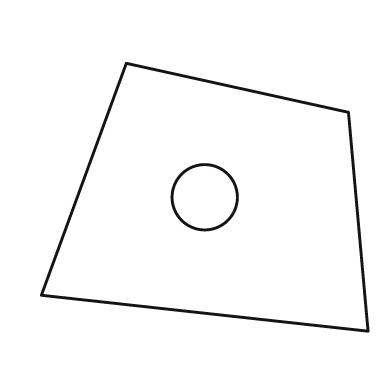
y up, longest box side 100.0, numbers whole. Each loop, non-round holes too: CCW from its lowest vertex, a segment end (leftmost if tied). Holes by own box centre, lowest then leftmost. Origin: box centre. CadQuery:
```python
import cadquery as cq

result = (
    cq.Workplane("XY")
    .moveTo(50.0, -41.0)
    .lineTo(44.0, 26.0)
    .lineTo(-24.0, 41.0)
    .lineTo(-50.0, -30.0)
    .close()
    .moveTo(0.0, 0.0)
    .circle(10.0)
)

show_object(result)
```